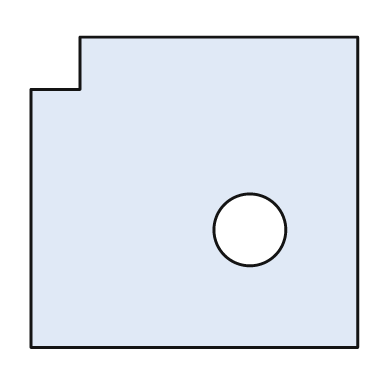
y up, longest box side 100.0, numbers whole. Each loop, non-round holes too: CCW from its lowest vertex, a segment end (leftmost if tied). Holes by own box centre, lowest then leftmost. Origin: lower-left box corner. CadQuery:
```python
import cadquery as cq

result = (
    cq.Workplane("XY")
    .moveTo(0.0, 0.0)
    .lineTo(100.0, 0.0)
    .lineTo(100.0, 95.0)
    .lineTo(15.0, 95.0)
    .lineTo(15.0, 79.0)
    .lineTo(0.0, 79.0)
    .close()
    .moveTo(67.0, 36.0)
    .circle(11.0)
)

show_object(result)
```